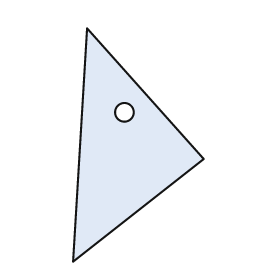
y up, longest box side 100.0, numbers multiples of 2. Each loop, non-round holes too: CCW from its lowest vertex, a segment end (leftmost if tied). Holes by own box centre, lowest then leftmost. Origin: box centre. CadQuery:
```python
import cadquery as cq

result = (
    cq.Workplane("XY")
    .moveTo(-28.0, -50.0)
    .lineTo(28.0, -6.0)
    .lineTo(-22.0, 50.0)
    .close()
    .moveTo(-6.0, 14.0)
    .circle(4.0)
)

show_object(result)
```